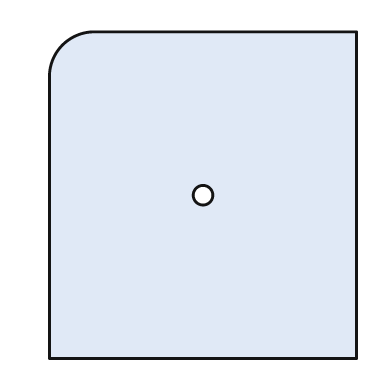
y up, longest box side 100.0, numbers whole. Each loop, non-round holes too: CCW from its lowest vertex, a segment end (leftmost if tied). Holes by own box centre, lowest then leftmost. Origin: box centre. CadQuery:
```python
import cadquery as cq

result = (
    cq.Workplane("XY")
    .moveTo(-47.0, -50.0)
    .lineTo(47.0, -50.0)
    .lineTo(47.0, 50.0)
    .lineTo(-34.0, 50.0)
    .threePointArc((-43.0, 46.0), (-47.0, 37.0))
    .close()
    .moveTo(0.0, 0.0)
    .circle(3.0)
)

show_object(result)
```